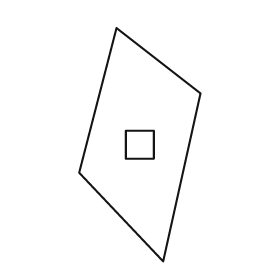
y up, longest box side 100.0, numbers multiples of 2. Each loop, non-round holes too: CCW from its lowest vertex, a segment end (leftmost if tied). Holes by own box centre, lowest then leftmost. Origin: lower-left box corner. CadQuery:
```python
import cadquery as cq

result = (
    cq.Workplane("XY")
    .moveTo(36.0, 0.0)
    .lineTo(52.0, 72.0)
    .lineTo(16.0, 100.0)
    .lineTo(0.0, 38.0)
    .close()
    .moveTo(20.0, 44.0)
    .lineTo(32.0, 44.0)
    .lineTo(32.0, 56.0)
    .lineTo(20.0, 56.0)
    .close()
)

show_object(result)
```